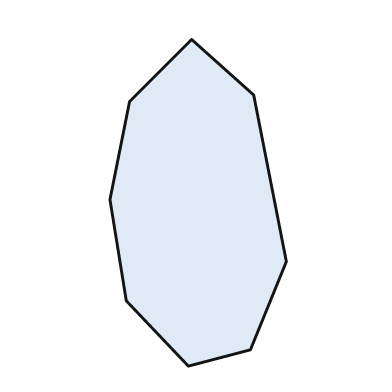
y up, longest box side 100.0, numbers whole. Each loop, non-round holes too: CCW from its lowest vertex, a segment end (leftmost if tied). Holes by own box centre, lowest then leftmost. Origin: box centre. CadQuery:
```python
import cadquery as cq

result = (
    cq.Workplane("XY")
    .moveTo(-3.0, -50.0)
    .lineTo(16.0, -45.0)
    .lineTo(27.0, -18.0)
    .lineTo(17.0, 33.0)
    .lineTo(-2.0, 50.0)
    .lineTo(-21.0, 31.0)
    .lineTo(-27.0, 1.0)
    .lineTo(-22.0, -30.0)
    .close()
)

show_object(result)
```